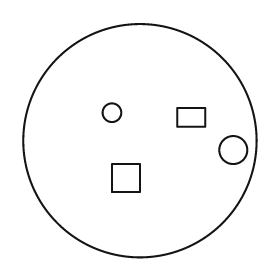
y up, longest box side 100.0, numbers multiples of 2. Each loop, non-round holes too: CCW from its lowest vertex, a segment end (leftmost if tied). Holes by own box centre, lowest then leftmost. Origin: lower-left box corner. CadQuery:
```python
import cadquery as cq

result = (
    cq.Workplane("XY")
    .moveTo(50.0, 50.0)
    .circle(50.0)
    .moveTo(38.0, 28.0)
    .lineTo(50.0, 28.0)
    .lineTo(50.0, 40.0)
    .lineTo(38.0, 40.0)
    .close()
    .moveTo(90.0, 46.0)
    .circle(6.0)
    .moveTo(66.0, 56.0)
    .lineTo(78.0, 56.0)
    .lineTo(78.0, 64.0)
    .lineTo(66.0, 64.0)
    .close()
    .moveTo(38.0, 62.0)
    .circle(4.0)
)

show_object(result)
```